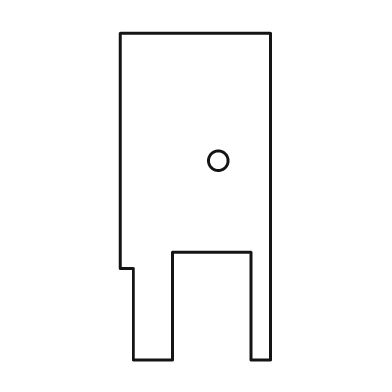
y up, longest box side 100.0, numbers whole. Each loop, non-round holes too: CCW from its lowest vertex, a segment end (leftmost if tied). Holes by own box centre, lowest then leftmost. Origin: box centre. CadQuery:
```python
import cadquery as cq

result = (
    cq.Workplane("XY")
    .moveTo(-19.0, -50.0)
    .lineTo(-7.0, -50.0)
    .lineTo(-7.0, -17.0)
    .lineTo(17.0, -17.0)
    .lineTo(17.0, -50.0)
    .lineTo(23.0, -50.0)
    .lineTo(23.0, 50.0)
    .lineTo(-23.0, 50.0)
    .lineTo(-23.0, -22.0)
    .lineTo(-19.0, -22.0)
    .close()
    .moveTo(7.0, 11.0)
    .circle(3.0)
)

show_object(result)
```